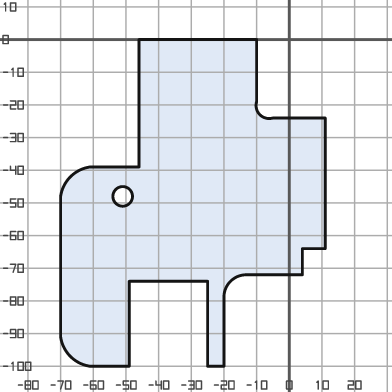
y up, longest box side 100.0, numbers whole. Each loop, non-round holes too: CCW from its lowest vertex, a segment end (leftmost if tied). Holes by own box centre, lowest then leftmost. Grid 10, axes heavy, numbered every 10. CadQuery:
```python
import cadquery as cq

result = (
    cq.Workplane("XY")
    .moveTo(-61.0, -100.0)
    .lineTo(-49.0, -100.0)
    .lineTo(-49.0, -74.0)
    .lineTo(-25.0, -74.0)
    .lineTo(-25.0, -100.0)
    .lineTo(-20.0, -100.0)
    .lineTo(-20.0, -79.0)
    .threePointArc((-18.0, -74.0), (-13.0, -72.0))
    .lineTo(4.0, -72.0)
    .lineTo(4.0, -64.0)
    .lineTo(11.0, -64.0)
    .lineTo(11.0, -24.0)
    .lineTo(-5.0, -24.0)
    .threePointArc((-9.0, -23.0), (-10.0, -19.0))
    .lineTo(-10.0, 0.0)
    .lineTo(-46.0, 0.0)
    .lineTo(-46.0, -39.0)
    .lineTo(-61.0, -39.0)
    .threePointArc((-67.0, -42.0), (-70.0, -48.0))
    .lineTo(-70.0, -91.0)
    .threePointArc((-67.0, -97.0), (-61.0, -100.0))
    .close()
    .moveTo(-51.0, -48.0)
    .circle(3.0)
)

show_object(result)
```